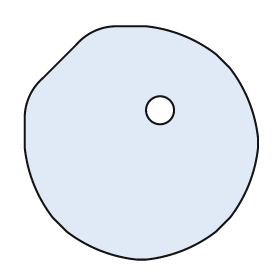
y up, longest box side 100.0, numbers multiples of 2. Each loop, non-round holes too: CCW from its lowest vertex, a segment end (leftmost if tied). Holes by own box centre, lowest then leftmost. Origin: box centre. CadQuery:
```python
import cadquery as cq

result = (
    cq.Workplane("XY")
    .moveTo(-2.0, -50.0)
    .lineTo(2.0, -50.0)
    .threePointArc((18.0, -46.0), (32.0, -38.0))
    .lineTo(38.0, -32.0)
    .threePointArc((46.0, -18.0), (50.0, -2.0))
    .lineTo(50.0, 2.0)
    .threePointArc((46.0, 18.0), (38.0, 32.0))
    .lineTo(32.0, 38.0)
    .threePointArc((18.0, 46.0), (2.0, 50.0))
    .lineTo(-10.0, 50.0)
    .threePointArc((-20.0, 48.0), (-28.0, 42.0))
    .lineTo(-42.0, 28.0)
    .threePointArc((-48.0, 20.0), (-50.0, 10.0))
    .lineTo(-50.0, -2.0)
    .threePointArc((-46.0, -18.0), (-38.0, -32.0))
    .lineTo(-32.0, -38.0)
    .threePointArc((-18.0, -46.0), (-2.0, -50.0))
    .close()
    .moveTo(8.0, 14.0)
    .circle(6.0)
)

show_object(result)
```